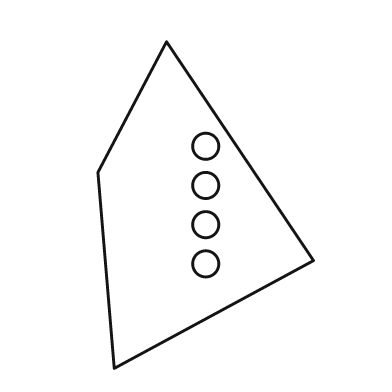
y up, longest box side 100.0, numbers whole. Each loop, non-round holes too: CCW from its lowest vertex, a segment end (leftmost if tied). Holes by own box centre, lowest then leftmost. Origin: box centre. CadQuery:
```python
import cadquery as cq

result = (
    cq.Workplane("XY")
    .moveTo(-28.0, -50.0)
    .lineTo(33.0, -17.0)
    .lineTo(-12.0, 50.0)
    .lineTo(-33.0, 10.0)
    .close()
    .moveTo(0.0, -18.0)
    .circle(4.0)
    .moveTo(0.0, -6.0)
    .circle(4.0)
    .moveTo(0.0, 6.0)
    .circle(4.0)
    .moveTo(0.0, 18.0)
    .circle(4.0)
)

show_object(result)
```